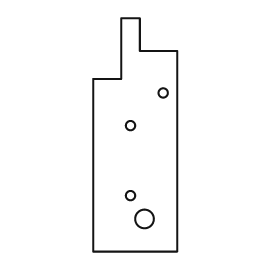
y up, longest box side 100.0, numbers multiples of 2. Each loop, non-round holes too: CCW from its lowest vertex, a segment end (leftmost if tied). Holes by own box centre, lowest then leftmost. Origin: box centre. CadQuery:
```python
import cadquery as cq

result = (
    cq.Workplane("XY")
    .moveTo(-18.0, -50.0)
    .lineTo(18.0, -50.0)
    .lineTo(18.0, 36.0)
    .lineTo(2.0, 36.0)
    .lineTo(2.0, 50.0)
    .lineTo(-6.0, 50.0)
    .lineTo(-6.0, 24.0)
    .lineTo(-18.0, 24.0)
    .close()
    .moveTo(4.0, -36.0)
    .circle(4.0)
    .moveTo(-2.0, -26.0)
    .circle(2.0)
    .moveTo(-2.0, 4.0)
    .circle(2.0)
    .moveTo(12.0, 18.0)
    .circle(2.0)
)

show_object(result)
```